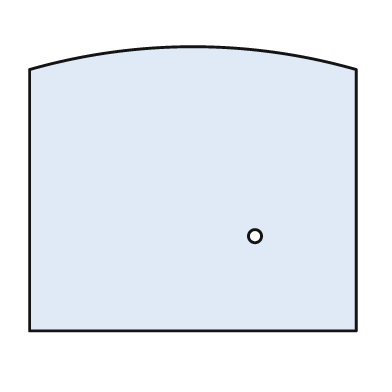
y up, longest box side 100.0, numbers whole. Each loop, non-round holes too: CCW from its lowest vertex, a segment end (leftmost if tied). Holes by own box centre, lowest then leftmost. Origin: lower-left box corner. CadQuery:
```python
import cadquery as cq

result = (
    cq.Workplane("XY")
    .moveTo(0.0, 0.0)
    .lineTo(100.0, 0.0)
    .lineTo(100.0, 80.0)
    .threePointArc((50.0, 87.0), (0.0, 80.0))
    .close()
    .moveTo(69.0, 29.0)
    .circle(2.0)
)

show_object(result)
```